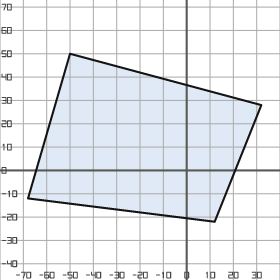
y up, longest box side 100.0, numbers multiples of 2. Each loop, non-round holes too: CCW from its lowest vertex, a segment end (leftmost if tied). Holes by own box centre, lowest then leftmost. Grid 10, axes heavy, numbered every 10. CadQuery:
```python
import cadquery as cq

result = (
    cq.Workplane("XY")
    .moveTo(12.0, -22.0)
    .lineTo(32.0, 28.0)
    .lineTo(-50.0, 50.0)
    .lineTo(-68.0, -12.0)
    .close()
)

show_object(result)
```